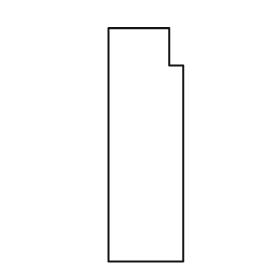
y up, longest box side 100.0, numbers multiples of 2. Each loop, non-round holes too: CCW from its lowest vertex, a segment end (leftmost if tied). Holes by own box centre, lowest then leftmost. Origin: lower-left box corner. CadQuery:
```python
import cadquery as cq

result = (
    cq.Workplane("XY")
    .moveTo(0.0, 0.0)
    .lineTo(32.0, 0.0)
    .lineTo(32.0, 84.0)
    .lineTo(26.0, 84.0)
    .lineTo(26.0, 100.0)
    .lineTo(0.0, 100.0)
    .close()
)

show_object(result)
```